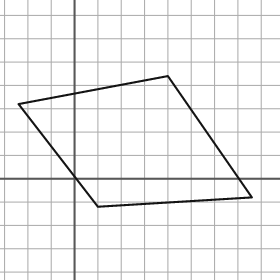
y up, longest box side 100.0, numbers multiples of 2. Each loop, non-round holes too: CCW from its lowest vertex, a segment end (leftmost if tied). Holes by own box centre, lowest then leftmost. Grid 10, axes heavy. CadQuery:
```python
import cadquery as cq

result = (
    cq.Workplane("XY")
    .moveTo(10.0, -12.0)
    .lineTo(76.0, -8.0)
    .lineTo(40.0, 44.0)
    .lineTo(-24.0, 32.0)
    .close()
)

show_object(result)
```